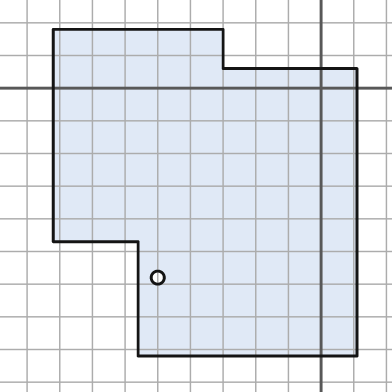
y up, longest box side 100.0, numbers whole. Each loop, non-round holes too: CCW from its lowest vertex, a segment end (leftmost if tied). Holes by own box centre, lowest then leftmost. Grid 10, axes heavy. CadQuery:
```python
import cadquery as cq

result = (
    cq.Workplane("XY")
    .moveTo(-56.0, -82.0)
    .lineTo(11.0, -82.0)
    .lineTo(11.0, 6.0)
    .lineTo(-30.0, 6.0)
    .lineTo(-30.0, 18.0)
    .lineTo(-82.0, 18.0)
    .lineTo(-82.0, -47.0)
    .lineTo(-56.0, -47.0)
    .close()
    .moveTo(-50.0, -58.0)
    .circle(2.0)
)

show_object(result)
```